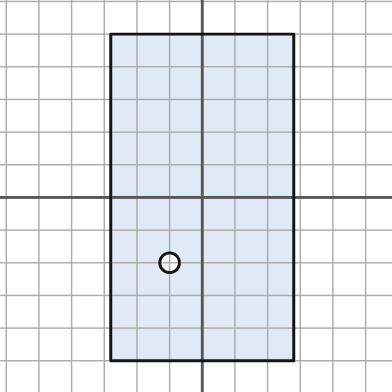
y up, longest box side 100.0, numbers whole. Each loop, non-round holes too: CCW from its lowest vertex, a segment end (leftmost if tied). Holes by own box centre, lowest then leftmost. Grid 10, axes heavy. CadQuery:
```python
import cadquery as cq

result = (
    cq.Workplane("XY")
    .moveTo(-28.0, -50.0)
    .lineTo(28.0, -50.0)
    .lineTo(28.0, 50.0)
    .lineTo(-28.0, 50.0)
    .close()
    .moveTo(-10.0, -20.0)
    .circle(3.0)
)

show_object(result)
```